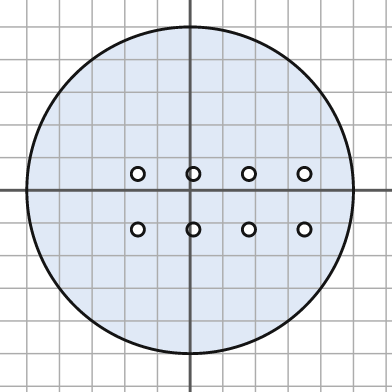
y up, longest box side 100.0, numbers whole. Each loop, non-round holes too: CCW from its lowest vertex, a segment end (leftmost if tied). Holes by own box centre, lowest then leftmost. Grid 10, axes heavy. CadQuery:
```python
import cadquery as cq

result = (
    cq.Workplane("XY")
    .moveTo(0.0, 0.0)
    .circle(50.0)
    .moveTo(-16.0, -12.0)
    .circle(2.0)
    .moveTo(1.0, -12.0)
    .circle(2.0)
    .moveTo(18.0, -12.0)
    .circle(2.0)
    .moveTo(35.0, -12.0)
    .circle(2.0)
    .moveTo(-16.0, 5.0)
    .circle(2.0)
    .moveTo(1.0, 5.0)
    .circle(2.0)
    .moveTo(18.0, 5.0)
    .circle(2.0)
    .moveTo(35.0, 5.0)
    .circle(2.0)
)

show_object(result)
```